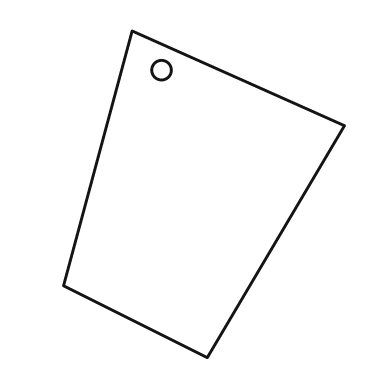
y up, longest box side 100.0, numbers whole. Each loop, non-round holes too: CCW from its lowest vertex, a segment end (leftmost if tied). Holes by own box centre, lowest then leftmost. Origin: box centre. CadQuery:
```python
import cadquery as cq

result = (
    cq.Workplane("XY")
    .moveTo(1.0, -50.0)
    .lineTo(43.0, 21.0)
    .lineTo(-22.0, 50.0)
    .lineTo(-43.0, -28.0)
    .close()
    .moveTo(-13.0, 38.0)
    .circle(3.0)
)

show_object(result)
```